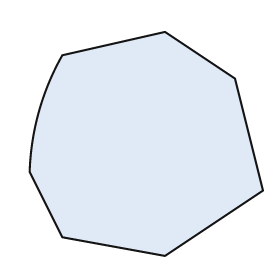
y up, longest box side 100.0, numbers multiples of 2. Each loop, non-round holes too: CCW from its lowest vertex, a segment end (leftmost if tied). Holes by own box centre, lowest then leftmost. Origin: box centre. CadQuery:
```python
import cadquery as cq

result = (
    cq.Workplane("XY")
    .moveTo(8.0, -48.0)
    .lineTo(50.0, -20.0)
    .lineTo(38.0, 28.0)
    .lineTo(8.0, 48.0)
    .lineTo(-36.0, 38.0)
    .threePointArc((-46.0, 14.0), (-50.0, -12.0))
    .lineTo(-36.0, -40.0)
    .close()
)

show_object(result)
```